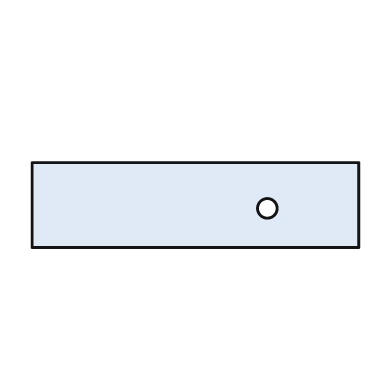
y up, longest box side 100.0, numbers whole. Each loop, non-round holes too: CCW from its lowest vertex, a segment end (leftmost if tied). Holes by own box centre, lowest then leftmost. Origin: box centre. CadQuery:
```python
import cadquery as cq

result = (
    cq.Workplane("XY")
    .moveTo(-50.0, -13.0)
    .lineTo(50.0, -13.0)
    .lineTo(50.0, 13.0)
    .lineTo(-50.0, 13.0)
    .close()
    .moveTo(22.0, -1.0)
    .circle(3.0)
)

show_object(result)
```